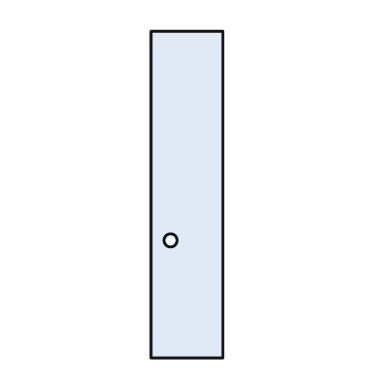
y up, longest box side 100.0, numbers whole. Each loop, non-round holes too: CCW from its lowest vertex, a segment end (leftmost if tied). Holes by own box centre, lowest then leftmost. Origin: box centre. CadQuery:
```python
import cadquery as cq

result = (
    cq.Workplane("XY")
    .moveTo(-11.0, -50.0)
    .lineTo(11.0, -50.0)
    .lineTo(11.0, 50.0)
    .lineTo(-11.0, 50.0)
    .close()
    .moveTo(-5.0, -14.0)
    .circle(2.0)
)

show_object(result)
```